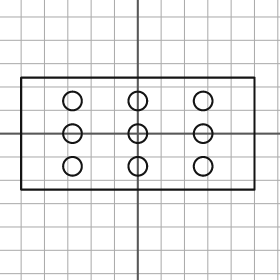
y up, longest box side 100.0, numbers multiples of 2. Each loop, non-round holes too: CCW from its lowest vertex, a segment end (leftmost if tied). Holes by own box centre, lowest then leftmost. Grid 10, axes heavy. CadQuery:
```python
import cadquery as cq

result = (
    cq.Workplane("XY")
    .moveTo(-50.0, -24.0)
    .lineTo(50.0, -24.0)
    .lineTo(50.0, 24.0)
    .lineTo(-50.0, 24.0)
    .close()
    .moveTo(-28.0, -14.0)
    .circle(4.0)
    .moveTo(0.0, -14.0)
    .circle(4.0)
    .moveTo(28.0, -14.0)
    .circle(4.0)
    .moveTo(-28.0, 0.0)
    .circle(4.0)
    .moveTo(0.0, 0.0)
    .circle(4.0)
    .moveTo(28.0, 0.0)
    .circle(4.0)
    .moveTo(-28.0, 14.0)
    .circle(4.0)
    .moveTo(0.0, 14.0)
    .circle(4.0)
    .moveTo(28.0, 14.0)
    .circle(4.0)
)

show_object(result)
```